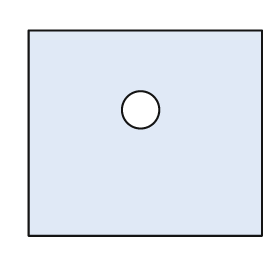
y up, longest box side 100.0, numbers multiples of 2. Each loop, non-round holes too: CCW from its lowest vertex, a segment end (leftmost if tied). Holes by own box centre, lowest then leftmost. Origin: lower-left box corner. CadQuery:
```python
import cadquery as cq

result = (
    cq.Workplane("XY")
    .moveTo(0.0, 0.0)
    .lineTo(100.0, 0.0)
    .lineTo(100.0, 88.0)
    .lineTo(0.0, 88.0)
    .close()
    .moveTo(48.0, 54.0)
    .circle(8.0)
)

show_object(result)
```